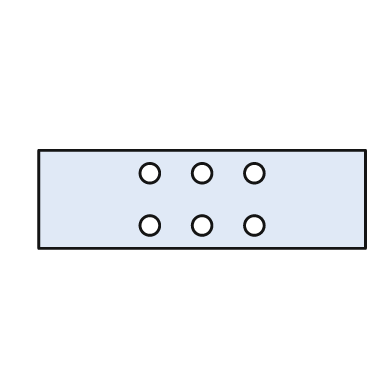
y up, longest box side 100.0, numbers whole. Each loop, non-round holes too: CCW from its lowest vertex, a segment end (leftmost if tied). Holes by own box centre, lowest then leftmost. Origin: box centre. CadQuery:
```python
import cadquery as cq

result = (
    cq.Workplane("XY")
    .moveTo(-50.0, -15.0)
    .lineTo(50.0, -15.0)
    .lineTo(50.0, 15.0)
    .lineTo(-50.0, 15.0)
    .close()
    .moveTo(-16.0, -8.0)
    .circle(3.0)
    .moveTo(0.0, -8.0)
    .circle(3.0)
    .moveTo(16.0, -8.0)
    .circle(3.0)
    .moveTo(-16.0, 8.0)
    .circle(3.0)
    .moveTo(0.0, 8.0)
    .circle(3.0)
    .moveTo(16.0, 8.0)
    .circle(3.0)
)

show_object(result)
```